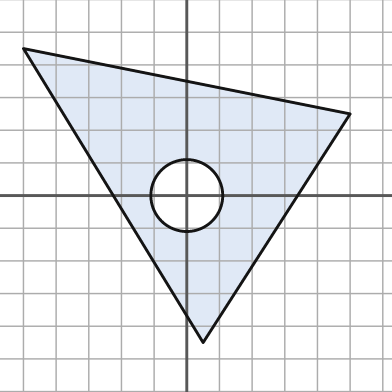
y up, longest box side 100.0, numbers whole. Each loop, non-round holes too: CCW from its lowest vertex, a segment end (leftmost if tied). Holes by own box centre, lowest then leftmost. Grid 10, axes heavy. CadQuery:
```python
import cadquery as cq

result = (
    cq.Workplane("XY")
    .moveTo(5.0, -45.0)
    .lineTo(50.0, 25.0)
    .lineTo(-50.0, 45.0)
    .close()
    .moveTo(0.0, 0.0)
    .circle(11.0)
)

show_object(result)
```